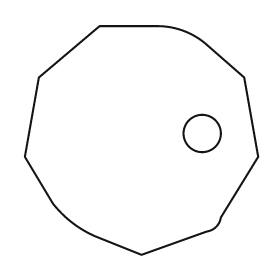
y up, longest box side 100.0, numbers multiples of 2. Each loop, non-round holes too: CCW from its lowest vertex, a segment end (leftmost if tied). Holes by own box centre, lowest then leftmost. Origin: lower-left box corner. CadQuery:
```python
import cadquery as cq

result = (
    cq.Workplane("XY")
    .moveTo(50.0, 0.0)
    .lineTo(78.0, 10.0)
    .threePointArc((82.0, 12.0), (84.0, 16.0))
    .lineTo(100.0, 42.0)
    .lineTo(94.0, 76.0)
    .lineTo(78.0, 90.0)
    .threePointArc((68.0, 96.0), (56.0, 98.0))
    .lineTo(32.0, 98.0)
    .lineTo(6.0, 76.0)
    .lineTo(0.0, 42.0)
    .lineTo(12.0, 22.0)
    .threePointArc((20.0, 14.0), (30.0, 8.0))
    .close()
    .moveTo(76.0, 52.0)
    .circle(8.0)
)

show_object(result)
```